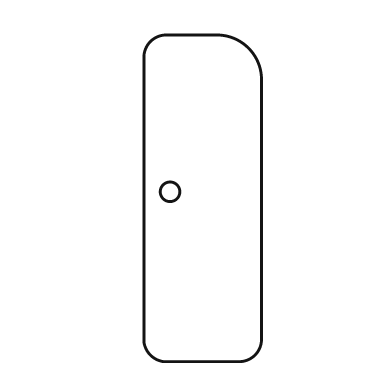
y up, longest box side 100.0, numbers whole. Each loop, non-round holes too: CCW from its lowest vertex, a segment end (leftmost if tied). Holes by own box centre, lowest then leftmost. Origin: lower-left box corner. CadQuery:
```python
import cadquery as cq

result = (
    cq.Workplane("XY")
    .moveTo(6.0, 0.0)
    .lineTo(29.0, 0.0)
    .threePointArc((34.0, 2.0), (36.0, 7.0))
    .lineTo(36.0, 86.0)
    .threePointArc((32.0, 96.0), (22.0, 100.0))
    .lineTo(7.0, 100.0)
    .threePointArc((2.0, 98.0), (0.0, 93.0))
    .lineTo(0.0, 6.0)
    .threePointArc((2.0, 2.0), (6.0, 0.0))
    .close()
    .moveTo(8.0, 52.0)
    .circle(3.0)
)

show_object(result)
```